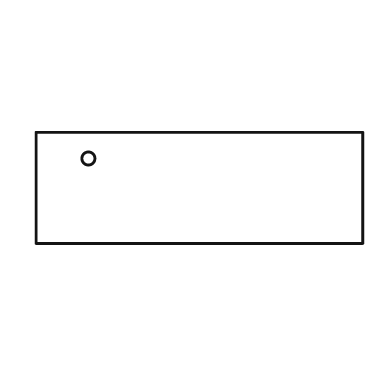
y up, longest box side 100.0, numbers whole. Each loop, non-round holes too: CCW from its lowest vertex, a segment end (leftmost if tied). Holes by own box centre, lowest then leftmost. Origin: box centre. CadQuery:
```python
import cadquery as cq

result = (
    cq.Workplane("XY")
    .moveTo(-50.0, -17.0)
    .lineTo(50.0, -17.0)
    .lineTo(50.0, 17.0)
    .lineTo(-50.0, 17.0)
    .close()
    .moveTo(-34.0, 9.0)
    .circle(2.0)
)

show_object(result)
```